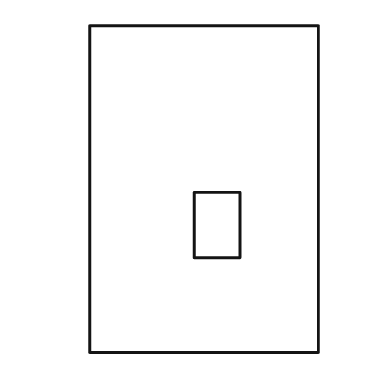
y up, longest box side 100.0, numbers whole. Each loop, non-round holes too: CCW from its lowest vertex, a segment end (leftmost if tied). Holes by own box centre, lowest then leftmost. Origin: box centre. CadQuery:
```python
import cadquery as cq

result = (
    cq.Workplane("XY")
    .moveTo(-35.0, -50.0)
    .lineTo(35.0, -50.0)
    .lineTo(35.0, 50.0)
    .lineTo(-35.0, 50.0)
    .close()
    .moveTo(-3.0, -21.0)
    .lineTo(11.0, -21.0)
    .lineTo(11.0, -1.0)
    .lineTo(-3.0, -1.0)
    .close()
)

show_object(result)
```